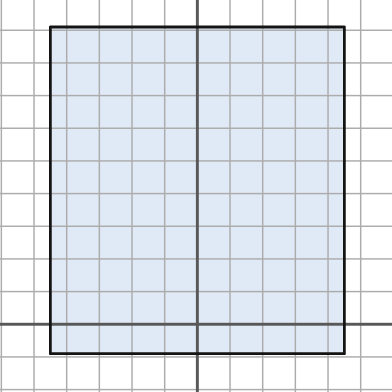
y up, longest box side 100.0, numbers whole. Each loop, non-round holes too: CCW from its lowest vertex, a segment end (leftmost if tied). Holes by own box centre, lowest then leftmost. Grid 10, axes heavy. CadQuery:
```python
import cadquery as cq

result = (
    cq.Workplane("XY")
    .moveTo(-45.0, -9.0)
    .lineTo(45.0, -9.0)
    .lineTo(45.0, 91.0)
    .lineTo(-45.0, 91.0)
    .close()
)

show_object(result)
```